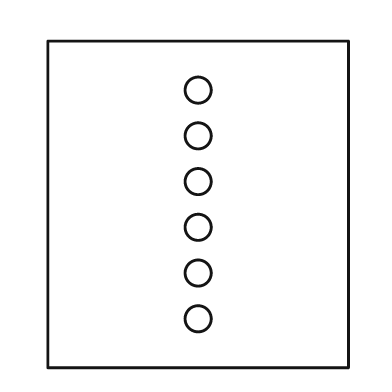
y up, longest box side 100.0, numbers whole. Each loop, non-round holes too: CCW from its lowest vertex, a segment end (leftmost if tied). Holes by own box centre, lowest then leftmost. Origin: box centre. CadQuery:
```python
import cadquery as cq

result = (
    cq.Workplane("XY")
    .moveTo(-46.0, -50.0)
    .lineTo(46.0, -50.0)
    .lineTo(46.0, 50.0)
    .lineTo(-46.0, 50.0)
    .close()
    .moveTo(0.0, -35.0)
    .circle(4.0)
    .moveTo(0.0, -21.0)
    .circle(4.0)
    .moveTo(0.0, -7.0)
    .circle(4.0)
    .moveTo(0.0, 7.0)
    .circle(4.0)
    .moveTo(0.0, 21.0)
    .circle(4.0)
    .moveTo(0.0, 35.0)
    .circle(4.0)
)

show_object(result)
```